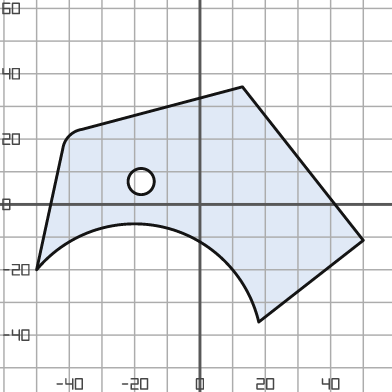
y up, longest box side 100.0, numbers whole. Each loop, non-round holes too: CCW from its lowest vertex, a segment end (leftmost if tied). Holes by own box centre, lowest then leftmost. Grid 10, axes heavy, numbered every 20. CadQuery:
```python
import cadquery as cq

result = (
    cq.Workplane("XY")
    .moveTo(18.0, -36.0)
    .lineTo(50.0, -11.0)
    .lineTo(13.0, 36.0)
    .lineTo(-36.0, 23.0)
    .threePointArc((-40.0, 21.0), (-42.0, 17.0))
    .lineTo(-50.0, -20.0)
    .threePointArc((-11.0, -7.0), (18.0, -36.0))
    .close()
    .moveTo(-18.0, 7.0)
    .circle(4.0)
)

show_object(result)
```